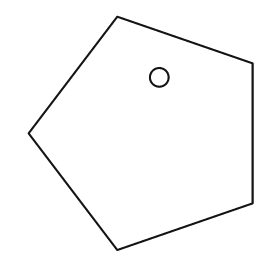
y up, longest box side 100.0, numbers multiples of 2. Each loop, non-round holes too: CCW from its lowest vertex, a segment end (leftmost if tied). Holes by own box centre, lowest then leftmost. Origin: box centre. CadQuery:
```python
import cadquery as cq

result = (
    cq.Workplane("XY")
    .moveTo(-10.0, -50.0)
    .lineTo(48.0, -30.0)
    .lineTo(48.0, 30.0)
    .lineTo(-10.0, 50.0)
    .lineTo(-48.0, 0.0)
    .close()
    .moveTo(8.0, 24.0)
    .circle(4.0)
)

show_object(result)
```